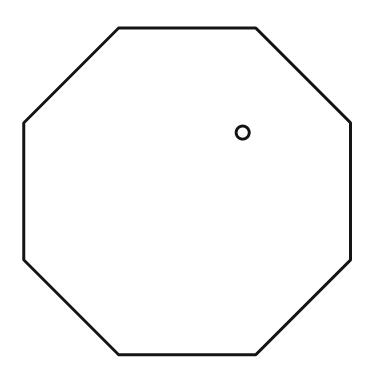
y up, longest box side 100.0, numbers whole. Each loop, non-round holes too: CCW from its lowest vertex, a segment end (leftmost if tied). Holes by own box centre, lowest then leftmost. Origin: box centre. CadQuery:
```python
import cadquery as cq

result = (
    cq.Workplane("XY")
    .moveTo(-21.0, -50.0)
    .lineTo(21.0, -50.0)
    .lineTo(50.0, -21.0)
    .lineTo(50.0, 21.0)
    .lineTo(21.0, 50.0)
    .lineTo(-21.0, 50.0)
    .lineTo(-50.0, 21.0)
    .lineTo(-50.0, -21.0)
    .close()
    .moveTo(17.0, 18.0)
    .circle(2.0)
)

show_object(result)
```